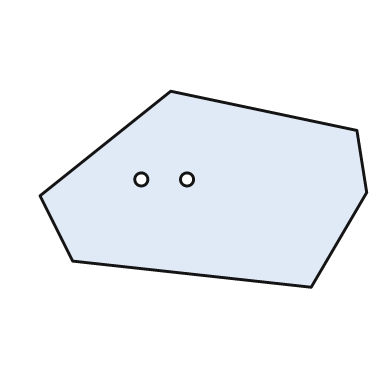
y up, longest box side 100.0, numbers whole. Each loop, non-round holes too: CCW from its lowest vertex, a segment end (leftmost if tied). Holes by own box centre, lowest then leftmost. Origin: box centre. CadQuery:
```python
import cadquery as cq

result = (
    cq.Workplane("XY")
    .moveTo(33.0, -30.0)
    .lineTo(50.0, -1.0)
    .lineTo(47.0, 18.0)
    .lineTo(-10.0, 30.0)
    .lineTo(-50.0, -2.0)
    .lineTo(-40.0, -22.0)
    .close()
    .moveTo(-19.0, 3.0)
    .circle(2.0)
    .moveTo(-5.0, 3.0)
    .circle(2.0)
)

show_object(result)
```